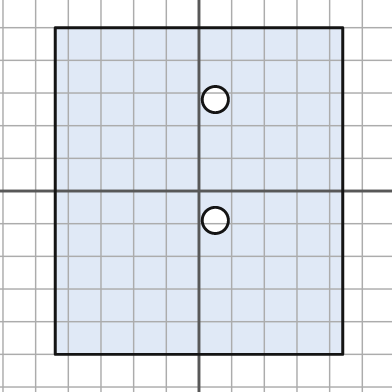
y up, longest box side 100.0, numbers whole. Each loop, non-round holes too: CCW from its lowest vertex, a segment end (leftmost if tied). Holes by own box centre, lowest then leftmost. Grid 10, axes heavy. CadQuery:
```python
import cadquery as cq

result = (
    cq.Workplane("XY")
    .moveTo(-44.0, -50.0)
    .lineTo(44.0, -50.0)
    .lineTo(44.0, 50.0)
    .lineTo(-44.0, 50.0)
    .close()
    .moveTo(5.0, -9.0)
    .circle(4.0)
    .moveTo(5.0, 28.0)
    .circle(4.0)
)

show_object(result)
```